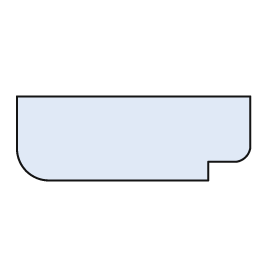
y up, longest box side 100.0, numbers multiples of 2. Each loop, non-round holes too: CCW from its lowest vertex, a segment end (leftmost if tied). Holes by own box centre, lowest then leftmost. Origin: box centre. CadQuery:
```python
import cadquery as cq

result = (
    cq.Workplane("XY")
    .moveTo(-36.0, -18.0)
    .lineTo(32.0, -18.0)
    .lineTo(32.0, -10.0)
    .lineTo(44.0, -10.0)
    .threePointArc((48.0, -8.0), (50.0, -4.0))
    .lineTo(50.0, 18.0)
    .lineTo(-50.0, 18.0)
    .lineTo(-50.0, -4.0)
    .threePointArc((-46.0, -14.0), (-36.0, -18.0))
    .close()
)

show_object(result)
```